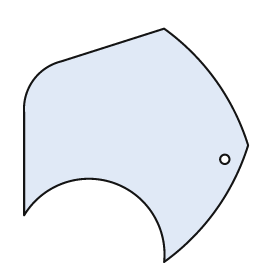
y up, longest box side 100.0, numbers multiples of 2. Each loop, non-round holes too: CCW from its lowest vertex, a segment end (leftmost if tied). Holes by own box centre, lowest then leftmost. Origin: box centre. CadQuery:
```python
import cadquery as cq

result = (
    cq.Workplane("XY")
    .moveTo(12.0, -50.0)
    .threePointArc((34.0, -28.0), (48.0, 0.0))
    .threePointArc((34.0, 28.0), (12.0, 50.0))
    .lineTo(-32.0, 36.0)
    .threePointArc((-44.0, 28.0), (-48.0, 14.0))
    .lineTo(-48.0, -30.0)
    .threePointArc((-10.0, -16.0), (12.0, -50.0))
    .close()
    .moveTo(38.0, -6.0)
    .circle(2.0)
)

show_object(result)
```